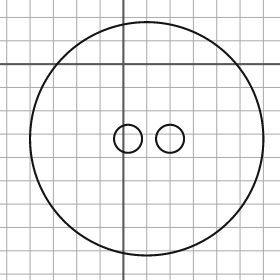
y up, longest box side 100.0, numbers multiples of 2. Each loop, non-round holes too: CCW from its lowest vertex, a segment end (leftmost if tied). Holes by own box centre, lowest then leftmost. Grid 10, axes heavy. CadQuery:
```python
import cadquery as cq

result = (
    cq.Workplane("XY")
    .moveTo(10.0, -32.0)
    .circle(50.0)
    .moveTo(2.0, -32.0)
    .circle(6.0)
    .moveTo(20.0, -32.0)
    .circle(6.0)
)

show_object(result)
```